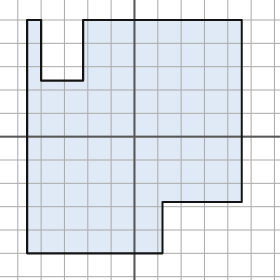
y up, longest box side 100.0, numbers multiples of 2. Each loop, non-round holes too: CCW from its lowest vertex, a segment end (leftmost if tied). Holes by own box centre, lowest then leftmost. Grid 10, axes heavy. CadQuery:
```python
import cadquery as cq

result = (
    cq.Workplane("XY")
    .moveTo(-46.0, -50.0)
    .lineTo(12.0, -50.0)
    .lineTo(12.0, -28.0)
    .lineTo(46.0, -28.0)
    .lineTo(46.0, 50.0)
    .lineTo(-22.0, 50.0)
    .lineTo(-22.0, 24.0)
    .lineTo(-40.0, 24.0)
    .lineTo(-40.0, 50.0)
    .lineTo(-46.0, 50.0)
    .close()
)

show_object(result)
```